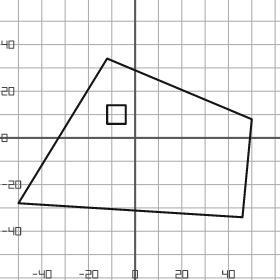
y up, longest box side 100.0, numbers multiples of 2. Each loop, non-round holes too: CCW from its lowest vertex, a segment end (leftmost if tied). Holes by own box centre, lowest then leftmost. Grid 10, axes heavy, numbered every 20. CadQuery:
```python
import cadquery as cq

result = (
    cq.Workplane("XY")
    .moveTo(46.0, -34.0)
    .lineTo(50.0, 8.0)
    .lineTo(-12.0, 34.0)
    .lineTo(-50.0, -28.0)
    .close()
    .moveTo(-12.0, 6.0)
    .lineTo(-4.0, 6.0)
    .lineTo(-4.0, 14.0)
    .lineTo(-12.0, 14.0)
    .close()
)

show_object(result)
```